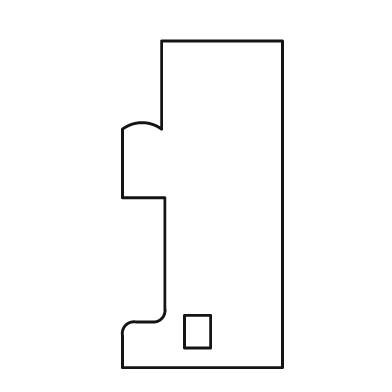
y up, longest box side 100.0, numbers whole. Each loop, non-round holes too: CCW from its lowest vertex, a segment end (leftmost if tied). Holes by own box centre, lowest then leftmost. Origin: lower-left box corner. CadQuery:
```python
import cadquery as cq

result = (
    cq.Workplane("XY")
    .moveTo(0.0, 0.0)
    .lineTo(49.0, 0.0)
    .lineTo(49.0, 100.0)
    .lineTo(12.0, 100.0)
    .lineTo(12.0, 73.0)
    .threePointArc((6.0, 75.0), (0.0, 73.0))
    .lineTo(0.0, 52.0)
    .lineTo(13.0, 52.0)
    .lineTo(13.0, 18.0)
    .threePointArc((12.0, 15.0), (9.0, 14.0))
    .lineTo(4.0, 14.0)
    .threePointArc((1.0, 13.0), (0.0, 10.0))
    .close()
    .moveTo(19.0, 6.0)
    .lineTo(27.0, 6.0)
    .lineTo(27.0, 16.0)
    .lineTo(19.0, 16.0)
    .close()
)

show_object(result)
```